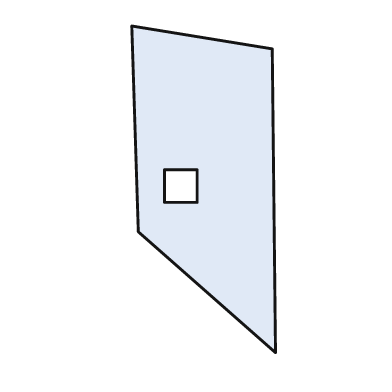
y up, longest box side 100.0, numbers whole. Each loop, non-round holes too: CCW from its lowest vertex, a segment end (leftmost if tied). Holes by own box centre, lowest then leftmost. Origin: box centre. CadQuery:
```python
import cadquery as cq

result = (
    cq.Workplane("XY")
    .moveTo(22.0, -50.0)
    .lineTo(21.0, 43.0)
    .lineTo(-22.0, 50.0)
    .lineTo(-20.0, -13.0)
    .close()
    .moveTo(-12.0, -4.0)
    .lineTo(-2.0, -4.0)
    .lineTo(-2.0, 6.0)
    .lineTo(-12.0, 6.0)
    .close()
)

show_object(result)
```